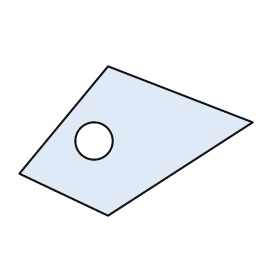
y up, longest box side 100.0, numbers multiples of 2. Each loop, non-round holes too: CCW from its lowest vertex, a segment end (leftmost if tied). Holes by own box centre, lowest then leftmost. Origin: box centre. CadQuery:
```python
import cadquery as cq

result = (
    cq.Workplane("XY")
    .moveTo(-12.0, -32.0)
    .lineTo(50.0, 8.0)
    .lineTo(-12.0, 32.0)
    .lineTo(-50.0, -14.0)
    .close()
    .moveTo(-18.0, 0.0)
    .circle(8.0)
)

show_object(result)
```